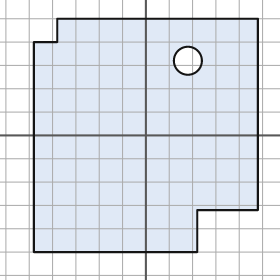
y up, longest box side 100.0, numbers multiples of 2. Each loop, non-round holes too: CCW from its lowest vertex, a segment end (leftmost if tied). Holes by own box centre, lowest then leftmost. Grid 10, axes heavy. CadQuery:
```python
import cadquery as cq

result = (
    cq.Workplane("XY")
    .moveTo(-48.0, -50.0)
    .lineTo(22.0, -50.0)
    .lineTo(22.0, -32.0)
    .lineTo(48.0, -32.0)
    .lineTo(48.0, 50.0)
    .lineTo(-38.0, 50.0)
    .lineTo(-38.0, 40.0)
    .lineTo(-48.0, 40.0)
    .close()
    .moveTo(18.0, 32.0)
    .circle(6.0)
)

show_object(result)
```